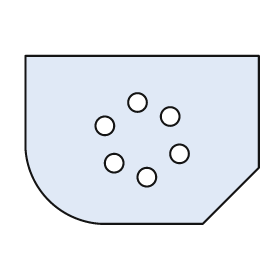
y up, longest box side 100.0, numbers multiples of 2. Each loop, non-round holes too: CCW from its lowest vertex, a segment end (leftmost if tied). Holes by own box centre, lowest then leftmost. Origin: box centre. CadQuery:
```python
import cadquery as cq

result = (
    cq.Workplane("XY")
    .moveTo(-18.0, -36.0)
    .lineTo(26.0, -36.0)
    .lineTo(50.0, -12.0)
    .lineTo(50.0, 36.0)
    .lineTo(-50.0, 36.0)
    .lineTo(-50.0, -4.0)
    .threePointArc((-40.0, -26.0), (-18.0, -36.0))
    .close()
    .moveTo(2.0, -16.0)
    .circle(4.0)
    .moveTo(-12.0, -10.0)
    .circle(4.0)
    .moveTo(16.0, -6.0)
    .circle(4.0)
    .moveTo(-16.0, 6.0)
    .circle(4.0)
    .moveTo(12.0, 10.0)
    .circle(4.0)
    .moveTo(-2.0, 16.0)
    .circle(4.0)
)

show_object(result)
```